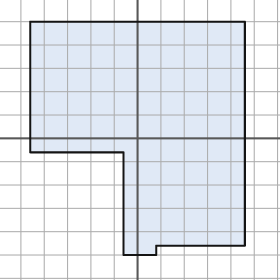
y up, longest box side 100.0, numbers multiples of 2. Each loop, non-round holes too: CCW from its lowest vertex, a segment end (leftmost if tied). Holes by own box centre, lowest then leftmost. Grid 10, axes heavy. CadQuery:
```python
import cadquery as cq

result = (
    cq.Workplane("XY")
    .moveTo(-6.0, -50.0)
    .lineTo(8.0, -50.0)
    .lineTo(8.0, -46.0)
    .lineTo(46.0, -46.0)
    .lineTo(46.0, 50.0)
    .lineTo(-46.0, 50.0)
    .lineTo(-46.0, -6.0)
    .lineTo(-6.0, -6.0)
    .close()
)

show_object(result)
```